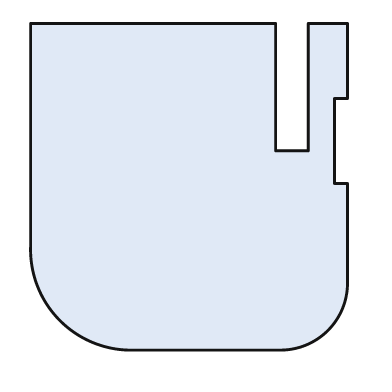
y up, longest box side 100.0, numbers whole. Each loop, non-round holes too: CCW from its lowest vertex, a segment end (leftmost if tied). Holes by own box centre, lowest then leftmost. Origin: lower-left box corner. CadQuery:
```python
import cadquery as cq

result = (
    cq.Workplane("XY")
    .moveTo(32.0, 0.0)
    .lineTo(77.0, 0.0)
    .threePointArc((91.0, 6.0), (97.0, 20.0))
    .lineTo(97.0, 51.0)
    .lineTo(93.0, 51.0)
    .lineTo(93.0, 77.0)
    .lineTo(97.0, 77.0)
    .lineTo(97.0, 100.0)
    .lineTo(85.0, 100.0)
    .lineTo(85.0, 61.0)
    .lineTo(75.0, 61.0)
    .lineTo(75.0, 100.0)
    .lineTo(0.0, 100.0)
    .lineTo(0.0, 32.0)
    .threePointArc((9.0, 9.0), (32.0, 0.0))
    .close()
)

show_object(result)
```